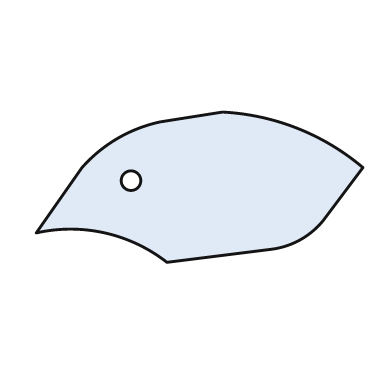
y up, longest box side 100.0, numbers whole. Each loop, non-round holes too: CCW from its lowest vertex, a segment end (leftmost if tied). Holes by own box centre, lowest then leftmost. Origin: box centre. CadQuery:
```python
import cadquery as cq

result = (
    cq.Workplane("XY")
    .moveTo(-10.0, -23.0)
    .lineTo(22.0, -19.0)
    .threePointArc((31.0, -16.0), (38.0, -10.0))
    .lineTo(50.0, 6.0)
    .threePointArc((30.0, 18.0), (7.0, 23.0))
    .lineTo(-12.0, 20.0)
    .threePointArc((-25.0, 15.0), (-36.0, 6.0))
    .lineTo(-50.0, -14.0)
    .threePointArc((-29.0, -14.0), (-10.0, -23.0))
    .close()
    .moveTo(-21.0, 2.0)
    .circle(3.0)
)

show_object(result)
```